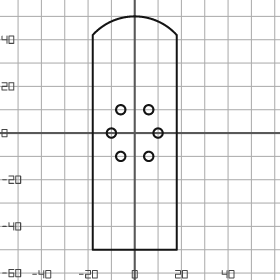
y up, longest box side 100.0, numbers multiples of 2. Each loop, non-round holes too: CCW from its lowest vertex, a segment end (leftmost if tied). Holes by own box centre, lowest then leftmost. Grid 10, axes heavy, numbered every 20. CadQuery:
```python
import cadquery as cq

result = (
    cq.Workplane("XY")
    .moveTo(-18.0, -50.0)
    .lineTo(18.0, -50.0)
    .lineTo(18.0, 42.0)
    .threePointArc((0.0, 50.0), (-18.0, 42.0))
    .close()
    .moveTo(-6.0, -10.0)
    .circle(2.0)
    .moveTo(6.0, -10.0)
    .circle(2.0)
    .moveTo(-10.0, 0.0)
    .circle(2.0)
    .moveTo(10.0, 0.0)
    .circle(2.0)
    .moveTo(-6.0, 10.0)
    .circle(2.0)
    .moveTo(6.0, 10.0)
    .circle(2.0)
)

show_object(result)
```